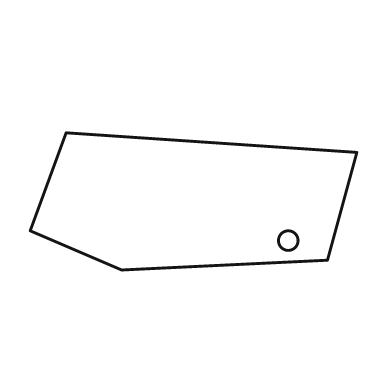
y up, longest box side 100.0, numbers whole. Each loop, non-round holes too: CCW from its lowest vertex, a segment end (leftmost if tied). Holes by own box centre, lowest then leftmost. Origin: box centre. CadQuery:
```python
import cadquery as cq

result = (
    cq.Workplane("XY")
    .moveTo(-22.0, -21.0)
    .lineTo(41.0, -18.0)
    .lineTo(50.0, 15.0)
    .lineTo(-39.0, 21.0)
    .lineTo(-50.0, -9.0)
    .close()
    .moveTo(29.0, -12.0)
    .circle(3.0)
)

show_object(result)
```